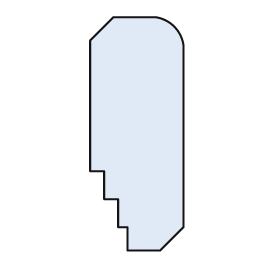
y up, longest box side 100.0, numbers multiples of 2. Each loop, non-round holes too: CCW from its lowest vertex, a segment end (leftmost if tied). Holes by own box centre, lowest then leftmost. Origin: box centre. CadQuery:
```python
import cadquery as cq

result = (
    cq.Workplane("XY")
    .moveTo(-4.0, -50.0)
    .lineTo(10.0, -50.0)
    .lineTo(20.0, -40.0)
    .lineTo(20.0, 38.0)
    .threePointArc((16.0, 46.0), (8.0, 50.0))
    .lineTo(-10.0, 50.0)
    .lineTo(-20.0, 40.0)
    .lineTo(-20.0, -16.0)
    .lineTo(-14.0, -16.0)
    .lineTo(-14.0, -28.0)
    .lineTo(-8.0, -28.0)
    .lineTo(-8.0, -40.0)
    .lineTo(-4.0, -40.0)
    .close()
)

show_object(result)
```